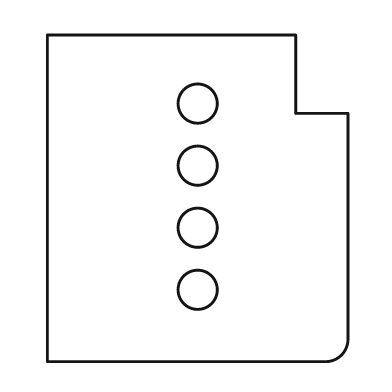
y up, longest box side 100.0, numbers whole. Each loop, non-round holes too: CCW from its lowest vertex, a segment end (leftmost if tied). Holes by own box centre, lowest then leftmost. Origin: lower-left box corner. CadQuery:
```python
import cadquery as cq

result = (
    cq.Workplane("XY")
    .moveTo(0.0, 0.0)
    .lineTo(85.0, 0.0)
    .threePointArc((90.0, 2.0), (92.0, 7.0))
    .lineTo(92.0, 76.0)
    .lineTo(76.0, 76.0)
    .lineTo(76.0, 100.0)
    .lineTo(0.0, 100.0)
    .close()
    .moveTo(46.0, 22.0)
    .circle(6.0)
    .moveTo(46.0, 41.0)
    .circle(6.0)
    .moveTo(46.0, 60.0)
    .circle(6.0)
    .moveTo(46.0, 79.0)
    .circle(6.0)
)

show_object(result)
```